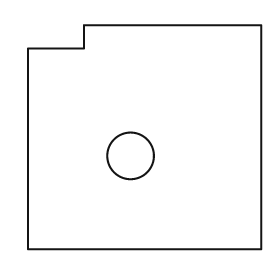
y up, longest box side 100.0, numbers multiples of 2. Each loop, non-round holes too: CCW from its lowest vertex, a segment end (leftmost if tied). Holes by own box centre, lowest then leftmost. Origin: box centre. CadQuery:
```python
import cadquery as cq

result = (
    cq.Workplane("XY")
    .moveTo(-50.0, -48.0)
    .lineTo(50.0, -48.0)
    .lineTo(50.0, 48.0)
    .lineTo(-26.0, 48.0)
    .lineTo(-26.0, 38.0)
    .lineTo(-50.0, 38.0)
    .close()
    .moveTo(-6.0, -8.0)
    .circle(10.0)
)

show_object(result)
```